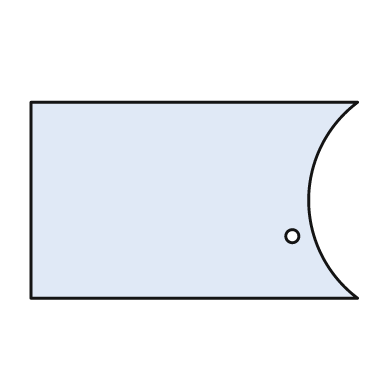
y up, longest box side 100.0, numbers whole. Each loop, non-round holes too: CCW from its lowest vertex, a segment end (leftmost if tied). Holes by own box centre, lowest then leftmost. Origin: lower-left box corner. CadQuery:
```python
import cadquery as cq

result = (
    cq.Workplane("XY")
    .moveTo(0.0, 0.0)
    .lineTo(100.0, 0.0)
    .threePointArc((85.0, 30.0), (100.0, 60.0))
    .lineTo(0.0, 60.0)
    .close()
    .moveTo(80.0, 19.0)
    .circle(2.0)
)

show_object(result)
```